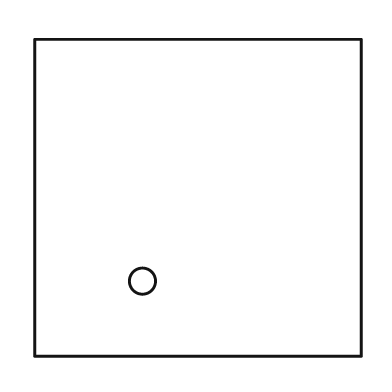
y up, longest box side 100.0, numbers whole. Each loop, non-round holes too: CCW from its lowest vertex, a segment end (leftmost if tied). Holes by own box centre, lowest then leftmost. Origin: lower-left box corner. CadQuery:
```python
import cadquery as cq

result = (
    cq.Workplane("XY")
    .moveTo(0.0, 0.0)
    .lineTo(100.0, 0.0)
    .lineTo(100.0, 97.0)
    .lineTo(0.0, 97.0)
    .close()
    .moveTo(33.0, 23.0)
    .circle(4.0)
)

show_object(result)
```